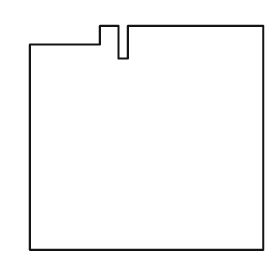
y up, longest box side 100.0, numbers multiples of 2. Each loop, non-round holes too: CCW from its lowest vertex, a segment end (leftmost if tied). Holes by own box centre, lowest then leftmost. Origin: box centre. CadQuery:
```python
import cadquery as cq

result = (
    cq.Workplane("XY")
    .moveTo(-50.0, -48.0)
    .lineTo(50.0, -48.0)
    .lineTo(50.0, 48.0)
    .lineTo(-8.0, 48.0)
    .lineTo(-8.0, 34.0)
    .lineTo(-12.0, 34.0)
    .lineTo(-12.0, 48.0)
    .lineTo(-20.0, 48.0)
    .lineTo(-20.0, 40.0)
    .lineTo(-50.0, 40.0)
    .close()
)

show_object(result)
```